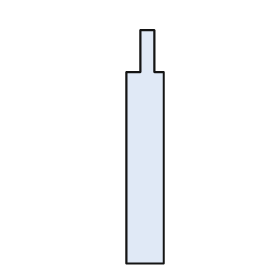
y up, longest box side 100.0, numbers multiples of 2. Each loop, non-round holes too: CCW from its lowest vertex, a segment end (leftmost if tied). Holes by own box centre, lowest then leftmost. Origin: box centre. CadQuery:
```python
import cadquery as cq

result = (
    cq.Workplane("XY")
    .moveTo(-8.0, -50.0)
    .lineTo(8.0, -50.0)
    .lineTo(8.0, 32.0)
    .lineTo(4.0, 32.0)
    .lineTo(4.0, 50.0)
    .lineTo(-2.0, 50.0)
    .lineTo(-2.0, 32.0)
    .lineTo(-8.0, 32.0)
    .close()
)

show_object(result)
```